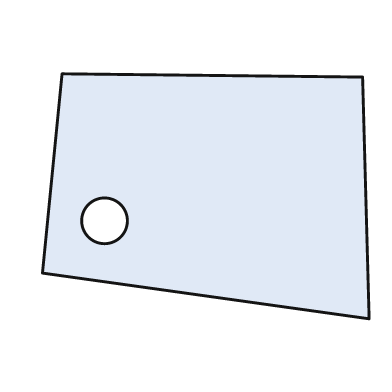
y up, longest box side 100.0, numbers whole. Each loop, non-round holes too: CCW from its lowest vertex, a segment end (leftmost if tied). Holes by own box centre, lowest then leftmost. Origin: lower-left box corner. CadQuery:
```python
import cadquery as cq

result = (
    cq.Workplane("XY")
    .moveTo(100.0, 0.0)
    .lineTo(98.0, 74.0)
    .lineTo(6.0, 75.0)
    .lineTo(0.0, 14.0)
    .close()
    .moveTo(19.0, 30.0)
    .circle(7.0)
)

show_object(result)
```